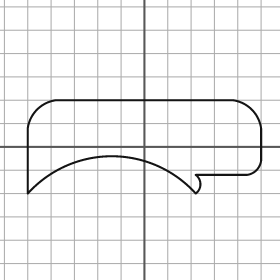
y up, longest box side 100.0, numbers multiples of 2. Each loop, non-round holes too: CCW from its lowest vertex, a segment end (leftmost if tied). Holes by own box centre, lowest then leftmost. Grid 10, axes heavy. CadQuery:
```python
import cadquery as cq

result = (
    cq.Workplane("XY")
    .moveTo(-50.0, -20.0)
    .threePointArc((-14.0, -4.0), (22.0, -20.0))
    .threePointArc((24.0, -16.0), (22.0, -12.0))
    .lineTo(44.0, -12.0)
    .threePointArc((48.0, -10.0), (50.0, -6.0))
    .lineTo(50.0, 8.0)
    .threePointArc((46.0, 16.0), (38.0, 20.0))
    .lineTo(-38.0, 20.0)
    .threePointArc((-46.0, 16.0), (-50.0, 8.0))
    .close()
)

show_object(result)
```